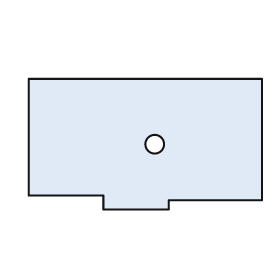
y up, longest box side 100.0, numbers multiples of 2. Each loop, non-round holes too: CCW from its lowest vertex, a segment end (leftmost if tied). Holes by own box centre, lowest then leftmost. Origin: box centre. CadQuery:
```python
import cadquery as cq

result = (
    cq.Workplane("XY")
    .moveTo(-18.0, -28.0)
    .lineTo(10.0, -28.0)
    .lineTo(10.0, -24.0)
    .lineTo(50.0, -24.0)
    .lineTo(50.0, 28.0)
    .lineTo(-50.0, 28.0)
    .lineTo(-50.0, -22.0)
    .lineTo(-18.0, -22.0)
    .close()
    .moveTo(4.0, 0.0)
    .circle(4.0)
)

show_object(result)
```